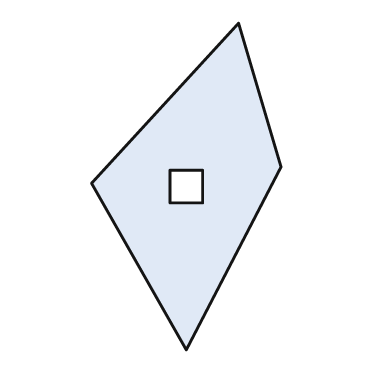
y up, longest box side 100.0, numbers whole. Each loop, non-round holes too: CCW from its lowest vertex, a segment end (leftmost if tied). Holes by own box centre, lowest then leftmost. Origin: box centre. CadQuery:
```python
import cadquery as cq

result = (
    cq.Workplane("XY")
    .moveTo(0.0, -50.0)
    .lineTo(29.0, 6.0)
    .lineTo(16.0, 50.0)
    .lineTo(-29.0, 1.0)
    .close()
    .moveTo(-5.0, -5.0)
    .lineTo(5.0, -5.0)
    .lineTo(5.0, 5.0)
    .lineTo(-5.0, 5.0)
    .close()
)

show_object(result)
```